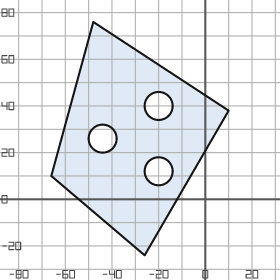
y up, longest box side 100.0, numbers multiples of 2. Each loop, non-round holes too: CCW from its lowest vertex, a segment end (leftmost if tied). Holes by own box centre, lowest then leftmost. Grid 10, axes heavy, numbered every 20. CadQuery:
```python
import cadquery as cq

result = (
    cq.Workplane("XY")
    .moveTo(-26.0, -24.0)
    .lineTo(10.0, 38.0)
    .lineTo(-48.0, 76.0)
    .lineTo(-66.0, 10.0)
    .close()
    .moveTo(-20.0, 12.0)
    .circle(6.0)
    .moveTo(-44.0, 26.0)
    .circle(6.0)
    .moveTo(-20.0, 40.0)
    .circle(6.0)
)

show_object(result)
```